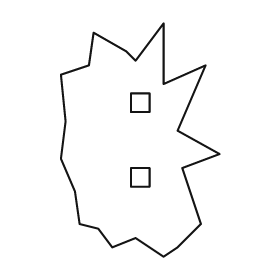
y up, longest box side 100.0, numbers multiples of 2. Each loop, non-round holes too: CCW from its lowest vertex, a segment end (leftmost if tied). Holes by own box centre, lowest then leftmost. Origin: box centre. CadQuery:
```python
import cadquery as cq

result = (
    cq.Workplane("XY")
    .moveTo(10.0, -50.0)
    .lineTo(16.0, -46.0)
    .lineTo(26.0, -36.0)
    .lineTo(18.0, -12.0)
    .lineTo(34.0, -6.0)
    .lineTo(16.0, 4.0)
    .lineTo(28.0, 32.0)
    .lineTo(10.0, 24.0)
    .lineTo(10.0, 50.0)
    .lineTo(-2.0, 34.0)
    .lineTo(-6.0, 38.0)
    .lineTo(-20.0, 46.0)
    .lineTo(-22.0, 32.0)
    .lineTo(-34.0, 28.0)
    .lineTo(-32.0, 8.0)
    .lineTo(-34.0, -8.0)
    .lineTo(-28.0, -22.0)
    .lineTo(-26.0, -36.0)
    .lineTo(-18.0, -38.0)
    .lineTo(-12.0, -46.0)
    .lineTo(-2.0, -42.0)
    .close()
    .moveTo(-4.0, -20.0)
    .lineTo(4.0, -20.0)
    .lineTo(4.0, -12.0)
    .lineTo(-4.0, -12.0)
    .close()
    .moveTo(-4.0, 12.0)
    .lineTo(4.0, 12.0)
    .lineTo(4.0, 20.0)
    .lineTo(-4.0, 20.0)
    .close()
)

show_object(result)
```